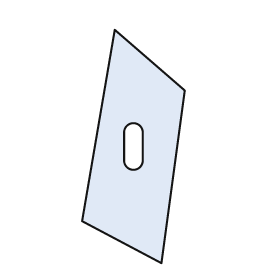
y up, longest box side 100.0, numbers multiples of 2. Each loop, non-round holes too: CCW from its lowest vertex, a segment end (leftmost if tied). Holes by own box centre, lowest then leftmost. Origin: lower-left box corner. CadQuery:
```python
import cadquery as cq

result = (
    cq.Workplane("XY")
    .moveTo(34.0, 0.0)
    .lineTo(44.0, 74.0)
    .lineTo(14.0, 100.0)
    .lineTo(0.0, 18.0)
    .close()
    .moveTo(18.0, 44.0)
    .threePointArc((22.0, 40.0), (26.0, 44.0))
    .lineTo(26.0, 56.0)
    .threePointArc((22.0, 60.0), (18.0, 56.0))
    .close()
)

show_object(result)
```